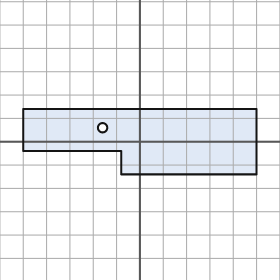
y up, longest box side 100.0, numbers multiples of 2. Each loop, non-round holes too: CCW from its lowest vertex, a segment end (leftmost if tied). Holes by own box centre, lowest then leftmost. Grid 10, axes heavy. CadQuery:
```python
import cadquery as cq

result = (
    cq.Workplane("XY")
    .moveTo(-8.0, -14.0)
    .lineTo(50.0, -14.0)
    .lineTo(50.0, 14.0)
    .lineTo(-50.0, 14.0)
    .lineTo(-50.0, -4.0)
    .lineTo(-8.0, -4.0)
    .close()
    .moveTo(-16.0, 6.0)
    .circle(2.0)
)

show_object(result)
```